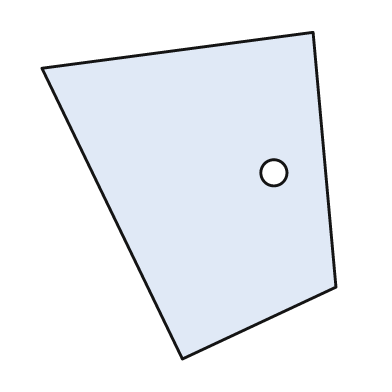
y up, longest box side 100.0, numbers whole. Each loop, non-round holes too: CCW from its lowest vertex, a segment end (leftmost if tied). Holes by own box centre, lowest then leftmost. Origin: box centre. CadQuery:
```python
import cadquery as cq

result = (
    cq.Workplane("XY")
    .moveTo(-2.0, -50.0)
    .lineTo(45.0, -28.0)
    .lineTo(38.0, 50.0)
    .lineTo(-45.0, 39.0)
    .close()
    .moveTo(26.0, 7.0)
    .circle(4.0)
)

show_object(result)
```